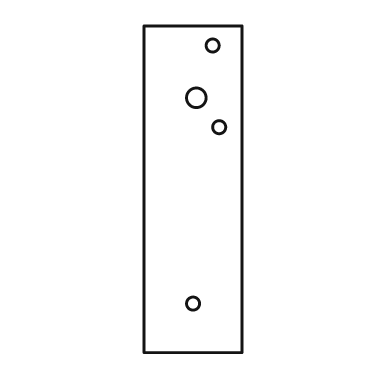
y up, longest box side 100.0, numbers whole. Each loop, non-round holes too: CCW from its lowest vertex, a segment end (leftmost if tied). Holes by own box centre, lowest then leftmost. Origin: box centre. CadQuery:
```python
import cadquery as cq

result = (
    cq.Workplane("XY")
    .moveTo(-15.0, -50.0)
    .lineTo(15.0, -50.0)
    .lineTo(15.0, 50.0)
    .lineTo(-15.0, 50.0)
    .close()
    .moveTo(0.0, -35.0)
    .circle(2.0)
    .moveTo(8.0, 19.0)
    .circle(2.0)
    .moveTo(1.0, 28.0)
    .circle(3.0)
    .moveTo(6.0, 44.0)
    .circle(2.0)
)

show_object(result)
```